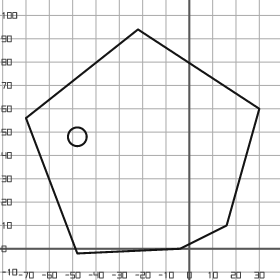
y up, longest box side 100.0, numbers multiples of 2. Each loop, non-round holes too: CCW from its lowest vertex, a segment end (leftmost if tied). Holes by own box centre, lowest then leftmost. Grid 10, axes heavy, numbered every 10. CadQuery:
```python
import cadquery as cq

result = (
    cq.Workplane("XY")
    .moveTo(-48.0, -2.0)
    .lineTo(-4.0, 0.0)
    .lineTo(16.0, 10.0)
    .lineTo(30.0, 60.0)
    .lineTo(-22.0, 94.0)
    .lineTo(-70.0, 56.0)
    .close()
    .moveTo(-48.0, 48.0)
    .circle(4.0)
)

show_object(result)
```